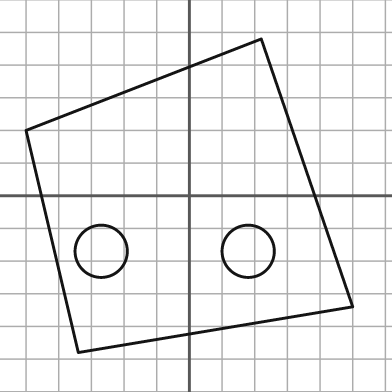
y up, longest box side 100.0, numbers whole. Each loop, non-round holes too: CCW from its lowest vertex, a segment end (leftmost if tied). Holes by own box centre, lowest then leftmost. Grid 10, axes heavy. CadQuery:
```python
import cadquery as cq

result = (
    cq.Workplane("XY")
    .moveTo(-34.0, -48.0)
    .lineTo(50.0, -34.0)
    .lineTo(22.0, 48.0)
    .lineTo(-50.0, 20.0)
    .close()
    .moveTo(-27.0, -17.0)
    .circle(8.0)
    .moveTo(18.0, -17.0)
    .circle(8.0)
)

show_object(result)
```